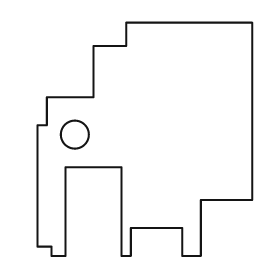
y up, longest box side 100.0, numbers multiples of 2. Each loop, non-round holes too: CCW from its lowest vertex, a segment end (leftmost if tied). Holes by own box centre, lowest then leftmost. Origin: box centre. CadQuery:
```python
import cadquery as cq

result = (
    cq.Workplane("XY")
    .moveTo(-40.0, -50.0)
    .lineTo(-34.0, -50.0)
    .lineTo(-34.0, -12.0)
    .lineTo(-10.0, -12.0)
    .lineTo(-10.0, -50.0)
    .lineTo(-6.0, -50.0)
    .lineTo(-6.0, -38.0)
    .lineTo(16.0, -38.0)
    .lineTo(16.0, -50.0)
    .lineTo(24.0, -50.0)
    .lineTo(24.0, -26.0)
    .lineTo(46.0, -26.0)
    .lineTo(46.0, 50.0)
    .lineTo(-8.0, 50.0)
    .lineTo(-8.0, 40.0)
    .lineTo(-22.0, 40.0)
    .lineTo(-22.0, 18.0)
    .lineTo(-42.0, 18.0)
    .lineTo(-42.0, 6.0)
    .lineTo(-46.0, 6.0)
    .lineTo(-46.0, -46.0)
    .lineTo(-40.0, -46.0)
    .close()
    .moveTo(-30.0, 2.0)
    .circle(6.0)
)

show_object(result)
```